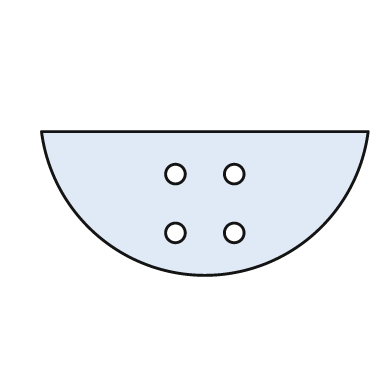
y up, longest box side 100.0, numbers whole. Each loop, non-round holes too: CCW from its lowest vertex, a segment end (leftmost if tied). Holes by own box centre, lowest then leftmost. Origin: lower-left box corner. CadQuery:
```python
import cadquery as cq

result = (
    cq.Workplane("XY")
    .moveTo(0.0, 44.0)
    .threePointArc((50.0, 0.0), (100.0, 44.0))
    .close()
    .moveTo(41.0, 13.0)
    .circle(3.0)
    .moveTo(59.0, 13.0)
    .circle(3.0)
    .moveTo(41.0, 31.0)
    .circle(3.0)
    .moveTo(59.0, 31.0)
    .circle(3.0)
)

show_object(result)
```